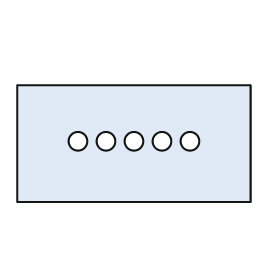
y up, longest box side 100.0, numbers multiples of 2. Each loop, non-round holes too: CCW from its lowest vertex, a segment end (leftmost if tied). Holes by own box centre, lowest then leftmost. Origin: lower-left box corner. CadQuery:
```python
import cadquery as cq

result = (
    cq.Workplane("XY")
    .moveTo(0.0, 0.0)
    .lineTo(100.0, 0.0)
    .lineTo(100.0, 50.0)
    .lineTo(0.0, 50.0)
    .close()
    .moveTo(26.0, 26.0)
    .circle(4.0)
    .moveTo(38.0, 26.0)
    .circle(4.0)
    .moveTo(50.0, 26.0)
    .circle(4.0)
    .moveTo(62.0, 26.0)
    .circle(4.0)
    .moveTo(74.0, 26.0)
    .circle(4.0)
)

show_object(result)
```